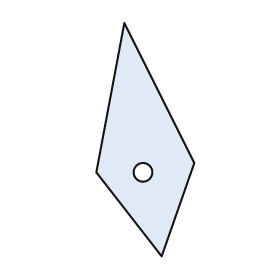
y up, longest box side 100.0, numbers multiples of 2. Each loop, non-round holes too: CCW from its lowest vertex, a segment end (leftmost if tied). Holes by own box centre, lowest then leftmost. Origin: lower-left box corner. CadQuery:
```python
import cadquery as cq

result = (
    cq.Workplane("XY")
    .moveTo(28.0, 0.0)
    .lineTo(42.0, 40.0)
    .lineTo(12.0, 100.0)
    .lineTo(0.0, 36.0)
    .close()
    .moveTo(20.0, 36.0)
    .circle(4.0)
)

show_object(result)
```